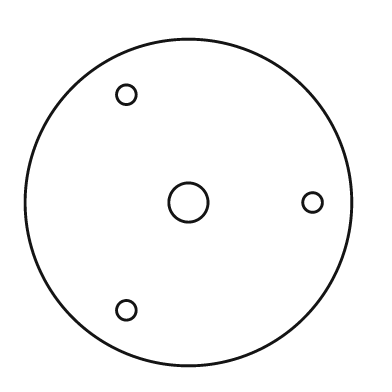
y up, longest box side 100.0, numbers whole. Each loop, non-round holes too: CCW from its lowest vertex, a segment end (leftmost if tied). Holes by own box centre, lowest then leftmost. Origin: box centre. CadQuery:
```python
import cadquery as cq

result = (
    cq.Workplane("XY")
    .moveTo(0.0, 0.0)
    .circle(50.0)
    .moveTo(-19.0, -33.0)
    .circle(3.0)
    .moveTo(0.0, 0.0)
    .circle(6.0)
    .moveTo(38.0, 0.0)
    .circle(3.0)
    .moveTo(-19.0, 33.0)
    .circle(3.0)
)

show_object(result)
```